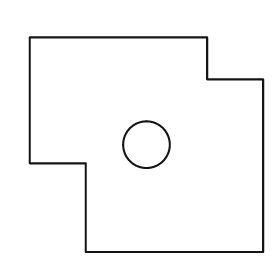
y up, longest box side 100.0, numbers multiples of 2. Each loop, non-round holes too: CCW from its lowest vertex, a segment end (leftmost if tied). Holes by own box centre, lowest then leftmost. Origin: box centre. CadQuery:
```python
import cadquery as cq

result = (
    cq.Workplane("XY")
    .moveTo(-26.0, -46.0)
    .lineTo(50.0, -46.0)
    .lineTo(50.0, 28.0)
    .lineTo(26.0, 28.0)
    .lineTo(26.0, 46.0)
    .lineTo(-50.0, 46.0)
    .lineTo(-50.0, -8.0)
    .lineTo(-26.0, -8.0)
    .close()
    .moveTo(0.0, 0.0)
    .circle(10.0)
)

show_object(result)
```